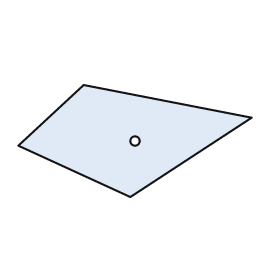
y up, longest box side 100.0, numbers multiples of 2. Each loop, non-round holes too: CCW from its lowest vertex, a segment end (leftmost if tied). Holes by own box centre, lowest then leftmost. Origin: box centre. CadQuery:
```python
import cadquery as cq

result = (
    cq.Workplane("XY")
    .moveTo(-2.0, -24.0)
    .lineTo(50.0, 10.0)
    .lineTo(-22.0, 24.0)
    .lineTo(-50.0, -2.0)
    .close()
    .moveTo(0.0, 0.0)
    .circle(2.0)
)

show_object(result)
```